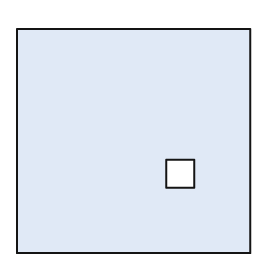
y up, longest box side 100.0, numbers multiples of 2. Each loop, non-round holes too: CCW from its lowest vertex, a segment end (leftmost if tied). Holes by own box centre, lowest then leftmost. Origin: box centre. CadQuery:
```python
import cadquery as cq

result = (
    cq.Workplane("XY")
    .moveTo(-50.0, -48.0)
    .lineTo(50.0, -48.0)
    .lineTo(50.0, 48.0)
    .lineTo(-50.0, 48.0)
    .close()
    .moveTo(14.0, -20.0)
    .lineTo(26.0, -20.0)
    .lineTo(26.0, -8.0)
    .lineTo(14.0, -8.0)
    .close()
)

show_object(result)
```